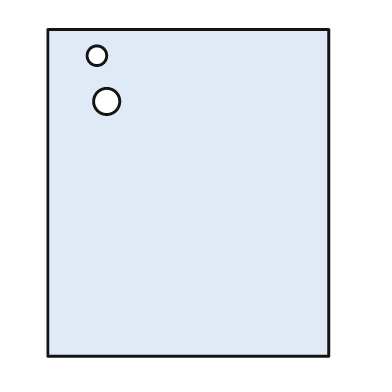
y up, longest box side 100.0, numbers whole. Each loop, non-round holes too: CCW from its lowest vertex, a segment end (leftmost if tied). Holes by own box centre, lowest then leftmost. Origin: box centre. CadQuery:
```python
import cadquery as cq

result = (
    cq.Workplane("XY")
    .moveTo(-43.0, -50.0)
    .lineTo(43.0, -50.0)
    .lineTo(43.0, 50.0)
    .lineTo(-43.0, 50.0)
    .close()
    .moveTo(-25.0, 28.0)
    .circle(4.0)
    .moveTo(-28.0, 42.0)
    .circle(3.0)
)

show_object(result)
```